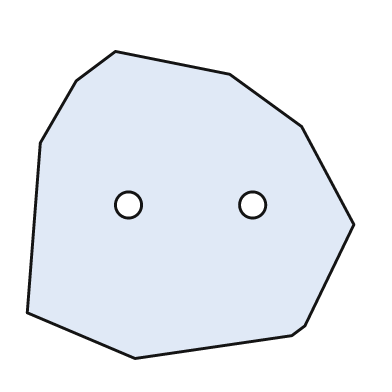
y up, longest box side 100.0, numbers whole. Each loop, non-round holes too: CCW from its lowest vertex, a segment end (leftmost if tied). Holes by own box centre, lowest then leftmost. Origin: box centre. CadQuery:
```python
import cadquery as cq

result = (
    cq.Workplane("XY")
    .moveTo(-17.0, -47.0)
    .lineTo(31.0, -40.0)
    .lineTo(35.0, -37.0)
    .lineTo(50.0, -6.0)
    .lineTo(34.0, 24.0)
    .lineTo(12.0, 40.0)
    .lineTo(-23.0, 47.0)
    .lineTo(-35.0, 38.0)
    .lineTo(-46.0, 19.0)
    .lineTo(-50.0, -33.0)
    .close()
    .moveTo(-19.0, 0.0)
    .circle(4.0)
    .moveTo(19.0, 0.0)
    .circle(4.0)
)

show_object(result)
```